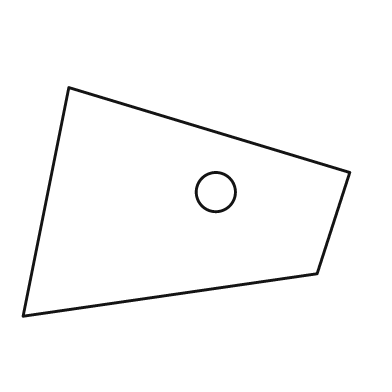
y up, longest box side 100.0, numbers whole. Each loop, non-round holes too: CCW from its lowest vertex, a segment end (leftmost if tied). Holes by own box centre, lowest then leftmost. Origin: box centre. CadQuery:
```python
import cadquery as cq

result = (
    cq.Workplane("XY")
    .moveTo(-50.0, -35.0)
    .lineTo(40.0, -22.0)
    .lineTo(50.0, 9.0)
    .lineTo(-36.0, 35.0)
    .close()
    .moveTo(9.0, 3.0)
    .circle(6.0)
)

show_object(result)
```